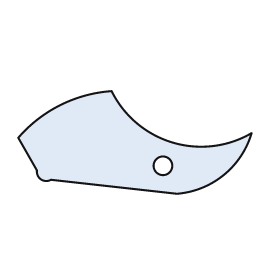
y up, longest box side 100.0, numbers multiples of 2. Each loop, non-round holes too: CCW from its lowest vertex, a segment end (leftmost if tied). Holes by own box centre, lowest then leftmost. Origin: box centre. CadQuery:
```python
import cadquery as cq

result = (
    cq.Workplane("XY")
    .moveTo(18.0, -22.0)
    .threePointArc((38.0, -14.0), (50.0, 4.0))
    .threePointArc((16.0, 0.0), (-10.0, 22.0))
    .threePointArc((-32.0, 16.0), (-50.0, 2.0))
    .lineTo(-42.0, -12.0)
    .threePointArc((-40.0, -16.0), (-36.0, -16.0))
    .close()
    .moveTo(12.0, -10.0)
    .circle(4.0)
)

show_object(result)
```